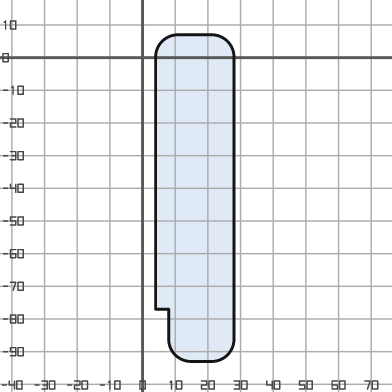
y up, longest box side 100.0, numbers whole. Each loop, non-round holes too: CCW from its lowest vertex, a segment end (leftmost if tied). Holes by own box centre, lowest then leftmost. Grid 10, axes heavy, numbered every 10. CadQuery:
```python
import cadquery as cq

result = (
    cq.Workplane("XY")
    .moveTo(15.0, -93.0)
    .lineTo(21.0, -93.0)
    .threePointArc((26.0, -91.0), (28.0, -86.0))
    .lineTo(28.0, 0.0)
    .threePointArc((26.0, 5.0), (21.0, 7.0))
    .lineTo(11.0, 7.0)
    .threePointArc((6.0, 5.0), (4.0, 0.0))
    .lineTo(4.0, -77.0)
    .lineTo(8.0, -77.0)
    .lineTo(8.0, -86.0)
    .threePointArc((10.0, -91.0), (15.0, -93.0))
    .close()
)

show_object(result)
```